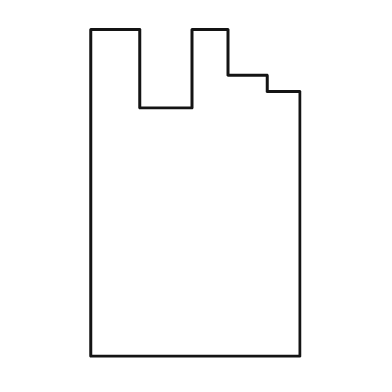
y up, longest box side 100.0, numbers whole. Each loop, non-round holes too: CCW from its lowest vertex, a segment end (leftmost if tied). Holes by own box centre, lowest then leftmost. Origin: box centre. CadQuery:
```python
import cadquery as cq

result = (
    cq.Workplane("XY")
    .moveTo(-32.0, -50.0)
    .lineTo(32.0, -50.0)
    .lineTo(32.0, 31.0)
    .lineTo(22.0, 31.0)
    .lineTo(22.0, 36.0)
    .lineTo(10.0, 36.0)
    .lineTo(10.0, 50.0)
    .lineTo(-1.0, 50.0)
    .lineTo(-1.0, 26.0)
    .lineTo(-17.0, 26.0)
    .lineTo(-17.0, 50.0)
    .lineTo(-32.0, 50.0)
    .close()
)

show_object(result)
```